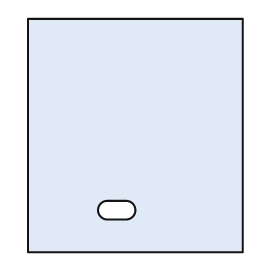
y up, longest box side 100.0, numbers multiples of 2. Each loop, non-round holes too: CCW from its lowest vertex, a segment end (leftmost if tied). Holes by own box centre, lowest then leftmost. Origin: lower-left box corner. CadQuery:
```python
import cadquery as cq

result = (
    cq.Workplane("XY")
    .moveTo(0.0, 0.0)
    .lineTo(92.0, 0.0)
    .lineTo(92.0, 100.0)
    .lineTo(0.0, 100.0)
    .close()
    .moveTo(34.0, 14.0)
    .lineTo(42.0, 14.0)
    .threePointArc((46.0, 18.0), (42.0, 22.0))
    .lineTo(34.0, 22.0)
    .threePointArc((30.0, 18.0), (34.0, 14.0))
    .close()
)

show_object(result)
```